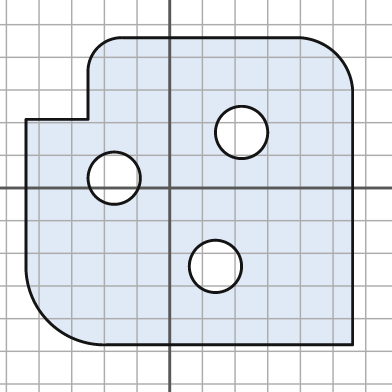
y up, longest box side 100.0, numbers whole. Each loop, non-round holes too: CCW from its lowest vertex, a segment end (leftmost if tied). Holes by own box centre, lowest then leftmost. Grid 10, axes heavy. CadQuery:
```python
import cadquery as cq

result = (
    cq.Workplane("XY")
    .moveTo(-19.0, -48.0)
    .lineTo(56.0, -48.0)
    .lineTo(56.0, 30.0)
    .threePointArc((51.0, 41.0), (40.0, 46.0))
    .lineTo(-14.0, 46.0)
    .threePointArc((-22.0, 43.0), (-25.0, 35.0))
    .lineTo(-25.0, 21.0)
    .lineTo(-44.0, 21.0)
    .lineTo(-44.0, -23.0)
    .threePointArc((-37.0, -41.0), (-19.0, -48.0))
    .close()
    .moveTo(14.0, -24.0)
    .circle(8.0)
    .moveTo(-17.0, 3.0)
    .circle(8.0)
    .moveTo(22.0, 17.0)
    .circle(8.0)
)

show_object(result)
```